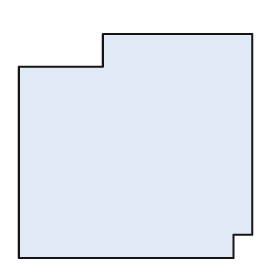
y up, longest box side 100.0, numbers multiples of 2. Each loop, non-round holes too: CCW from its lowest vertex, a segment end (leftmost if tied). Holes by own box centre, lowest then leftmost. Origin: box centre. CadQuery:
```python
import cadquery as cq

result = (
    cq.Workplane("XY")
    .moveTo(-50.0, -48.0)
    .lineTo(42.0, -48.0)
    .lineTo(42.0, -38.0)
    .lineTo(50.0, -38.0)
    .lineTo(50.0, 48.0)
    .lineTo(-14.0, 48.0)
    .lineTo(-14.0, 34.0)
    .lineTo(-50.0, 34.0)
    .close()
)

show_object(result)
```